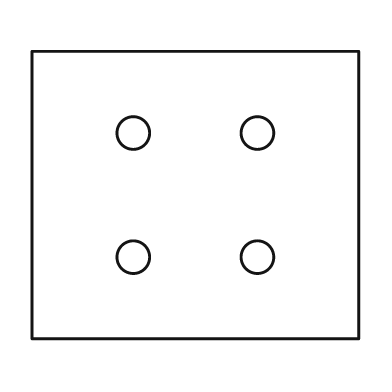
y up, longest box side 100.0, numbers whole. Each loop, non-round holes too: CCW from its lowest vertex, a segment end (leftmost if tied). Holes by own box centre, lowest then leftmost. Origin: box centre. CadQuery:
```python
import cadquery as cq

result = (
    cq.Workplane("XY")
    .moveTo(-50.0, -44.0)
    .lineTo(50.0, -44.0)
    .lineTo(50.0, 44.0)
    .lineTo(-50.0, 44.0)
    .close()
    .moveTo(-19.0, -19.0)
    .circle(5.0)
    .moveTo(19.0, -19.0)
    .circle(5.0)
    .moveTo(-19.0, 19.0)
    .circle(5.0)
    .moveTo(19.0, 19.0)
    .circle(5.0)
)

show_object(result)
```